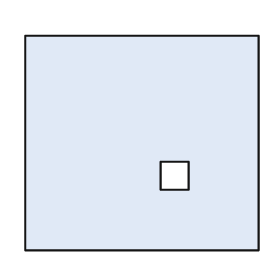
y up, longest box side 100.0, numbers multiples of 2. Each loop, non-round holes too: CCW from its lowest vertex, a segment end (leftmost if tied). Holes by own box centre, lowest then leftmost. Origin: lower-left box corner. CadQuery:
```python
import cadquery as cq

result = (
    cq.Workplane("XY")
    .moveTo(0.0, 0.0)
    .lineTo(100.0, 0.0)
    .lineTo(100.0, 92.0)
    .lineTo(0.0, 92.0)
    .close()
    .moveTo(58.0, 26.0)
    .lineTo(70.0, 26.0)
    .lineTo(70.0, 38.0)
    .lineTo(58.0, 38.0)
    .close()
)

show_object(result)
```